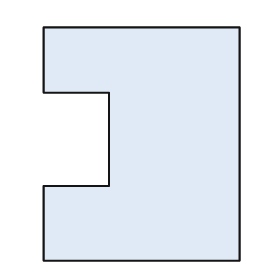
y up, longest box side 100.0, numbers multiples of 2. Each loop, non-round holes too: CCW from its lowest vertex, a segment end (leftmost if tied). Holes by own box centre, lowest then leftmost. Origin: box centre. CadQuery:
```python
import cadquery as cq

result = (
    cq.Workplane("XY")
    .moveTo(-42.0, -50.0)
    .lineTo(42.0, -50.0)
    .lineTo(42.0, 50.0)
    .lineTo(-42.0, 50.0)
    .lineTo(-42.0, 22.0)
    .lineTo(-14.0, 22.0)
    .lineTo(-14.0, -18.0)
    .lineTo(-42.0, -18.0)
    .close()
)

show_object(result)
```